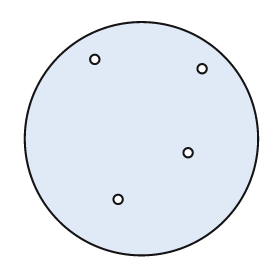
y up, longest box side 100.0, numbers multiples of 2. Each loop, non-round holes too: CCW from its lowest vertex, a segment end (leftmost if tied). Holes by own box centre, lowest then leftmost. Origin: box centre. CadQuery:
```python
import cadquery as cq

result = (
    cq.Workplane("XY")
    .moveTo(0.0, 0.0)
    .circle(50.0)
    .moveTo(-10.0, -26.0)
    .circle(2.0)
    .moveTo(20.0, -6.0)
    .circle(2.0)
    .moveTo(26.0, 30.0)
    .circle(2.0)
    .moveTo(-20.0, 34.0)
    .circle(2.0)
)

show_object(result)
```